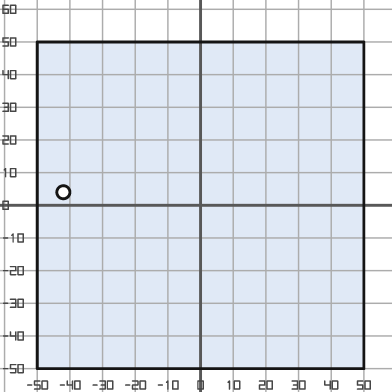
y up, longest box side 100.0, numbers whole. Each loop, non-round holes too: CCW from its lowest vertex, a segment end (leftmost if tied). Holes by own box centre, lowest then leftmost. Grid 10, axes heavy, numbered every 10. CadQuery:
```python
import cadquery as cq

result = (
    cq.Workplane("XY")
    .moveTo(-50.0, -50.0)
    .lineTo(50.0, -50.0)
    .lineTo(50.0, 50.0)
    .lineTo(-50.0, 50.0)
    .close()
    .moveTo(-42.0, 4.0)
    .circle(2.0)
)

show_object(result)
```